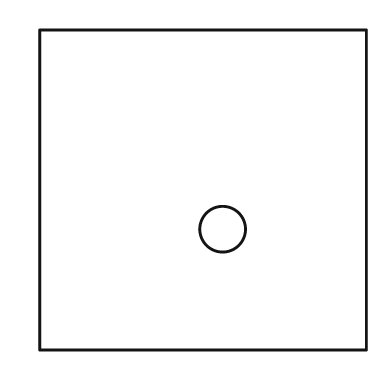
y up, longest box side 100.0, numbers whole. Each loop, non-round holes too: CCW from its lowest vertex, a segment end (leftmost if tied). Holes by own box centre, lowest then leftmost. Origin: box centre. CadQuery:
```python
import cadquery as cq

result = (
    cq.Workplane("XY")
    .moveTo(-50.0, -49.0)
    .lineTo(50.0, -49.0)
    .lineTo(50.0, 49.0)
    .lineTo(-50.0, 49.0)
    .close()
    .moveTo(6.0, -12.0)
    .circle(7.0)
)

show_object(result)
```